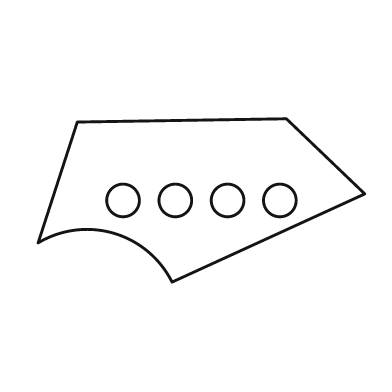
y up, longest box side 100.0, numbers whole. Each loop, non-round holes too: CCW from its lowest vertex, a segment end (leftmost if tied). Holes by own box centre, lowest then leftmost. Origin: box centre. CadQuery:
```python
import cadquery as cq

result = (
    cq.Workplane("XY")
    .moveTo(-9.0, -25.0)
    .lineTo(50.0, 2.0)
    .lineTo(26.0, 25.0)
    .lineTo(-38.0, 24.0)
    .lineTo(-50.0, -13.0)
    .threePointArc((-27.0, -10.0), (-9.0, -25.0))
    .close()
    .moveTo(-24.0, 0.0)
    .circle(5.0)
    .moveTo(-8.0, 0.0)
    .circle(5.0)
    .moveTo(8.0, 0.0)
    .circle(5.0)
    .moveTo(24.0, 0.0)
    .circle(5.0)
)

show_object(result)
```